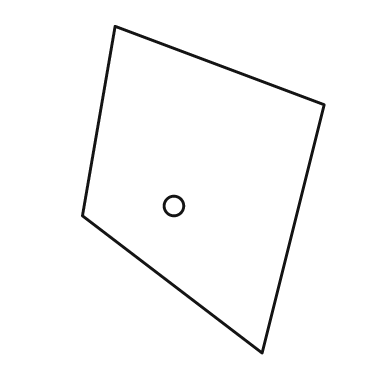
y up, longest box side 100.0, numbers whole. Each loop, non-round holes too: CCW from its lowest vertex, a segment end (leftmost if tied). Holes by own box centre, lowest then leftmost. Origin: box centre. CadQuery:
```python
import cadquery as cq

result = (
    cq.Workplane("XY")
    .moveTo(18.0, -50.0)
    .lineTo(37.0, 26.0)
    .lineTo(-27.0, 50.0)
    .lineTo(-37.0, -8.0)
    .close()
    .moveTo(-9.0, -5.0)
    .circle(3.0)
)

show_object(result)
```